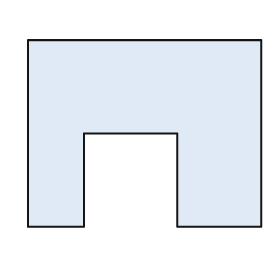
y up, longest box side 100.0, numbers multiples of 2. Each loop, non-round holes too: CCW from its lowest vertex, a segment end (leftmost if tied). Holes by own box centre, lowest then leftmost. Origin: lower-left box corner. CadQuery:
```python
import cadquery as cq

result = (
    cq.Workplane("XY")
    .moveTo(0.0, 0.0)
    .lineTo(24.0, 0.0)
    .lineTo(24.0, 40.0)
    .lineTo(64.0, 40.0)
    .lineTo(64.0, 0.0)
    .lineTo(100.0, 0.0)
    .lineTo(100.0, 80.0)
    .lineTo(0.0, 80.0)
    .close()
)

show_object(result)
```